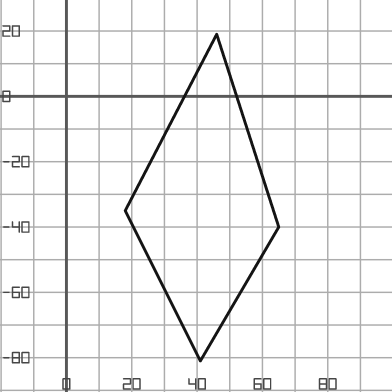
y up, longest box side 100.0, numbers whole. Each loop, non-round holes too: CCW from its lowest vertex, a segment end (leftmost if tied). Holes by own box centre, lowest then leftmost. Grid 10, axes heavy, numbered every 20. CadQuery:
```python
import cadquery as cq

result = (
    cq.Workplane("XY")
    .moveTo(41.0, -81.0)
    .lineTo(65.0, -40.0)
    .lineTo(46.0, 19.0)
    .lineTo(18.0, -35.0)
    .close()
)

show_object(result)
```